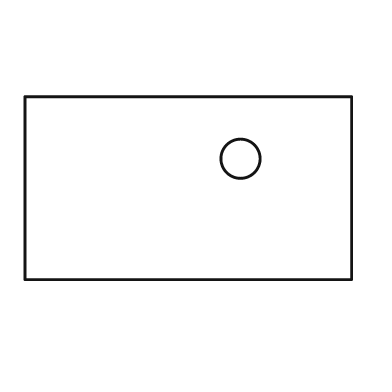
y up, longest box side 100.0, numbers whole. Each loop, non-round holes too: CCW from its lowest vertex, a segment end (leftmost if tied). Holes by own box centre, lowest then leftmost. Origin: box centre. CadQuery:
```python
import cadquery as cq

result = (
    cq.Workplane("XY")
    .moveTo(-50.0, -28.0)
    .lineTo(50.0, -28.0)
    .lineTo(50.0, 28.0)
    .lineTo(-50.0, 28.0)
    .close()
    .moveTo(16.0, 9.0)
    .circle(6.0)
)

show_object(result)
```